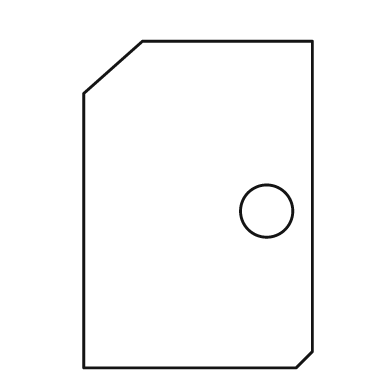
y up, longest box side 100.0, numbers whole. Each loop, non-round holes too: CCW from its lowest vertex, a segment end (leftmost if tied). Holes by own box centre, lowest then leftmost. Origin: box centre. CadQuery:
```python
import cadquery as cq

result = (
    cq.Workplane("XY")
    .moveTo(-35.0, -50.0)
    .lineTo(30.0, -50.0)
    .lineTo(35.0, -45.0)
    .lineTo(35.0, 50.0)
    .lineTo(-17.0, 50.0)
    .lineTo(-35.0, 34.0)
    .close()
    .moveTo(21.0, -2.0)
    .circle(8.0)
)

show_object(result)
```